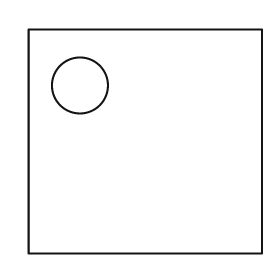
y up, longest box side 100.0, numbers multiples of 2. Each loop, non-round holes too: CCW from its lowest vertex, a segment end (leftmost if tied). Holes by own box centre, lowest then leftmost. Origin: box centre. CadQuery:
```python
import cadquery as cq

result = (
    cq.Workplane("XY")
    .moveTo(-50.0, -48.0)
    .lineTo(50.0, -48.0)
    .lineTo(50.0, 48.0)
    .lineTo(-50.0, 48.0)
    .close()
    .moveTo(-28.0, 24.0)
    .circle(12.0)
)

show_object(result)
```